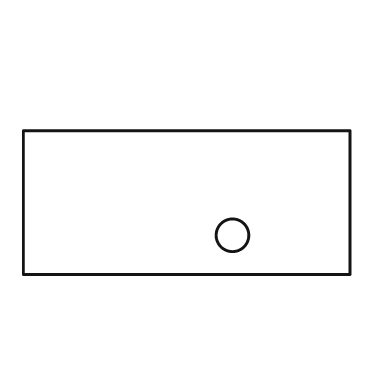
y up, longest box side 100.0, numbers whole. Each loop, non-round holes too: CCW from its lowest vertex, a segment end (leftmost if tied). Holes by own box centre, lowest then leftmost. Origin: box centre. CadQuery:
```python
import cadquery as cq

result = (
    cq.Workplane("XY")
    .moveTo(-50.0, -22.0)
    .lineTo(50.0, -22.0)
    .lineTo(50.0, 22.0)
    .lineTo(-50.0, 22.0)
    .close()
    .moveTo(14.0, -10.0)
    .circle(5.0)
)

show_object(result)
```